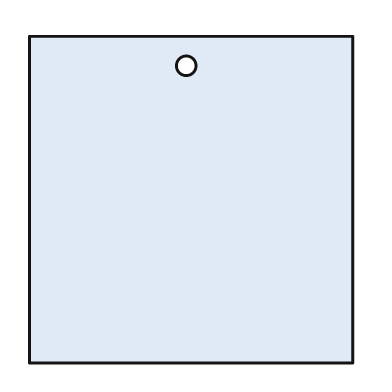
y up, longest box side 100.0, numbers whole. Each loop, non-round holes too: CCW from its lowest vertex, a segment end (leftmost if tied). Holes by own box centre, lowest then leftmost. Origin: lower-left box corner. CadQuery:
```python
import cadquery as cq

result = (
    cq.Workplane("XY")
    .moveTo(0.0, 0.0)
    .lineTo(99.0, 0.0)
    .lineTo(99.0, 100.0)
    .lineTo(0.0, 100.0)
    .close()
    .moveTo(48.0, 91.0)
    .circle(3.0)
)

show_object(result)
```